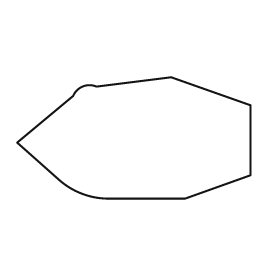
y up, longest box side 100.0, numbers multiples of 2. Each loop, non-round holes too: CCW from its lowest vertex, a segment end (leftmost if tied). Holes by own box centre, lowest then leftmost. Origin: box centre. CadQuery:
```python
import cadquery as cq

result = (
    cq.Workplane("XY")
    .moveTo(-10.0, -26.0)
    .lineTo(22.0, -26.0)
    .lineTo(50.0, -16.0)
    .lineTo(50.0, 14.0)
    .lineTo(16.0, 26.0)
    .lineTo(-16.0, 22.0)
    .threePointArc((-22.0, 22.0), (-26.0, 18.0))
    .lineTo(-50.0, -2.0)
    .lineTo(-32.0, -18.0)
    .threePointArc((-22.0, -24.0), (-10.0, -26.0))
    .close()
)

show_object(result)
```